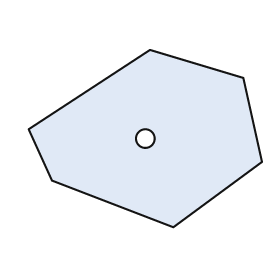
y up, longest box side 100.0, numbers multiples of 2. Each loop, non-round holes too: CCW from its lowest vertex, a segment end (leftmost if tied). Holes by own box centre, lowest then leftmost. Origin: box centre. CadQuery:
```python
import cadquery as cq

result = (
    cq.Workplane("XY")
    .moveTo(12.0, -38.0)
    .lineTo(50.0, -10.0)
    .lineTo(42.0, 26.0)
    .lineTo(2.0, 38.0)
    .lineTo(-50.0, 4.0)
    .lineTo(-40.0, -18.0)
    .close()
    .moveTo(0.0, 0.0)
    .circle(4.0)
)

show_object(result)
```